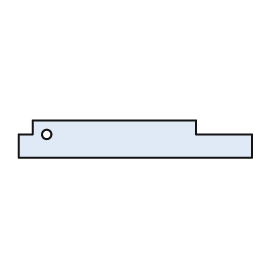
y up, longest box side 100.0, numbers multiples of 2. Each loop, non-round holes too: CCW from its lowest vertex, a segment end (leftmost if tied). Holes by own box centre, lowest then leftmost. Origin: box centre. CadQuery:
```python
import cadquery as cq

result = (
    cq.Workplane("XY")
    .moveTo(-50.0, -8.0)
    .lineTo(50.0, -8.0)
    .lineTo(50.0, 2.0)
    .lineTo(26.0, 2.0)
    .lineTo(26.0, 8.0)
    .lineTo(-44.0, 8.0)
    .lineTo(-44.0, 2.0)
    .lineTo(-50.0, 2.0)
    .close()
    .moveTo(-38.0, 2.0)
    .circle(2.0)
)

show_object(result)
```